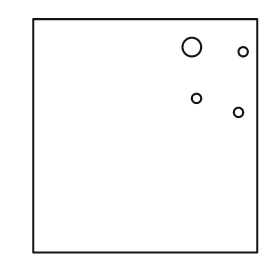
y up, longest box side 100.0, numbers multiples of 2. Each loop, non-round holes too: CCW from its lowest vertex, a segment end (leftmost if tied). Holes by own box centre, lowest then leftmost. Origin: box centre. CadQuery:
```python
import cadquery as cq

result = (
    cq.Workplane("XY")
    .moveTo(-48.0, -50.0)
    .lineTo(48.0, -50.0)
    .lineTo(48.0, 50.0)
    .lineTo(-48.0, 50.0)
    .close()
    .moveTo(40.0, 10.0)
    .circle(2.0)
    .moveTo(22.0, 16.0)
    .circle(2.0)
    .moveTo(42.0, 36.0)
    .circle(2.0)
    .moveTo(20.0, 38.0)
    .circle(4.0)
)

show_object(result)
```